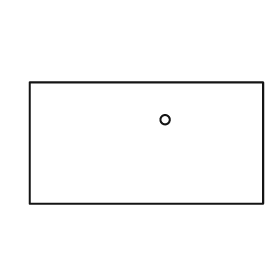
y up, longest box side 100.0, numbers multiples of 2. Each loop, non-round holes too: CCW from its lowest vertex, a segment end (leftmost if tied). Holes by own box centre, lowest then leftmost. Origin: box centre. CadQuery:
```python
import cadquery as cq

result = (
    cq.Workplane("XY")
    .moveTo(-50.0, -26.0)
    .lineTo(50.0, -26.0)
    .lineTo(50.0, 26.0)
    .lineTo(-50.0, 26.0)
    .close()
    .moveTo(8.0, 10.0)
    .circle(2.0)
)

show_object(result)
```